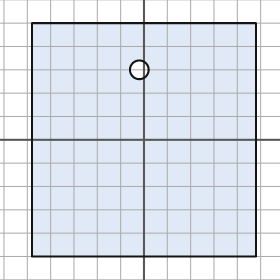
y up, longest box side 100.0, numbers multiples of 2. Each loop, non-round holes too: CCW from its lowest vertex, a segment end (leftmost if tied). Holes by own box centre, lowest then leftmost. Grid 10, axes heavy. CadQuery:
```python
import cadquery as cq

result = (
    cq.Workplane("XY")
    .moveTo(-48.0, -50.0)
    .lineTo(48.0, -50.0)
    .lineTo(48.0, 50.0)
    .lineTo(-48.0, 50.0)
    .close()
    .moveTo(-2.0, 30.0)
    .circle(4.0)
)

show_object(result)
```